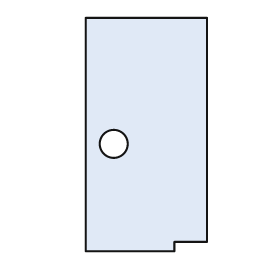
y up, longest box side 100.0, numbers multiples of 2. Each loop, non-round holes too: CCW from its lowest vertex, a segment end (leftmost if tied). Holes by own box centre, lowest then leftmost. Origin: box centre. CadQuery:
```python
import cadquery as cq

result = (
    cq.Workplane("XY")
    .moveTo(-26.0, -50.0)
    .lineTo(12.0, -50.0)
    .lineTo(12.0, -46.0)
    .lineTo(26.0, -46.0)
    .lineTo(26.0, 50.0)
    .lineTo(-26.0, 50.0)
    .close()
    .moveTo(-14.0, -4.0)
    .circle(6.0)
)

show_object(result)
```